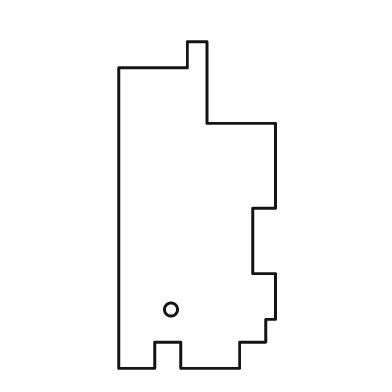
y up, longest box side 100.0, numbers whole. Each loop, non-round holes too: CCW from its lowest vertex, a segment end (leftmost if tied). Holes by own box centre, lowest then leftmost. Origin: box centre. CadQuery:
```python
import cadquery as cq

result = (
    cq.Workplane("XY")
    .moveTo(-24.0, -50.0)
    .lineTo(-13.0, -50.0)
    .lineTo(-13.0, -42.0)
    .lineTo(-5.0, -42.0)
    .lineTo(-5.0, -50.0)
    .lineTo(13.0, -50.0)
    .lineTo(13.0, -42.0)
    .lineTo(21.0, -42.0)
    .lineTo(21.0, -35.0)
    .lineTo(24.0, -35.0)
    .lineTo(24.0, -21.0)
    .lineTo(17.0, -21.0)
    .lineTo(17.0, -1.0)
    .lineTo(24.0, -1.0)
    .lineTo(24.0, 25.0)
    .lineTo(3.0, 25.0)
    .lineTo(3.0, 50.0)
    .lineTo(-3.0, 50.0)
    .lineTo(-3.0, 42.0)
    .lineTo(-24.0, 42.0)
    .close()
    .moveTo(-8.0, -32.0)
    .circle(2.0)
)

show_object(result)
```